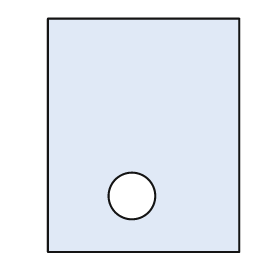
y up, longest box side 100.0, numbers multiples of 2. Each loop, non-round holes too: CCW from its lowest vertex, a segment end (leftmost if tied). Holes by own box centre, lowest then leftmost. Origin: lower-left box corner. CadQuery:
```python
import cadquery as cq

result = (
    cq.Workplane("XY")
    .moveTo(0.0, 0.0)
    .lineTo(82.0, 0.0)
    .lineTo(82.0, 100.0)
    .lineTo(0.0, 100.0)
    .close()
    .moveTo(36.0, 24.0)
    .circle(10.0)
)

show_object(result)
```